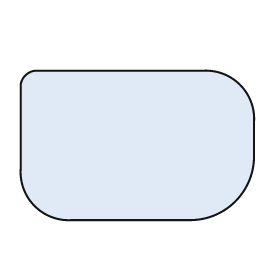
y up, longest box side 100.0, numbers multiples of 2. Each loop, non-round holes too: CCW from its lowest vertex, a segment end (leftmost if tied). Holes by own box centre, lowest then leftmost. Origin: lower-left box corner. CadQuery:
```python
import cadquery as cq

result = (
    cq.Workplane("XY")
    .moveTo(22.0, 0.0)
    .lineTo(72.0, 0.0)
    .threePointArc((92.0, 8.0), (100.0, 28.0))
    .lineTo(100.0, 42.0)
    .threePointArc((94.0, 58.0), (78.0, 64.0))
    .lineTo(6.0, 64.0)
    .threePointArc((2.0, 62.0), (0.0, 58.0))
    .lineTo(0.0, 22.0)
    .threePointArc((6.0, 6.0), (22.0, 0.0))
    .close()
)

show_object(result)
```